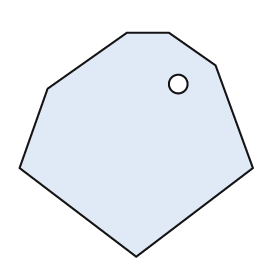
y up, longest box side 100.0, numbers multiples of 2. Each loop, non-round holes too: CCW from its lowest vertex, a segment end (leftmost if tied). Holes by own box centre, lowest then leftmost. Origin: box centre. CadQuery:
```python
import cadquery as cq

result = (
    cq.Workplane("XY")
    .moveTo(0.0, -48.0)
    .lineTo(50.0, -10.0)
    .lineTo(34.0, 34.0)
    .lineTo(14.0, 48.0)
    .lineTo(-4.0, 48.0)
    .lineTo(-38.0, 24.0)
    .lineTo(-50.0, -10.0)
    .close()
    .moveTo(18.0, 26.0)
    .circle(4.0)
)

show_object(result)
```